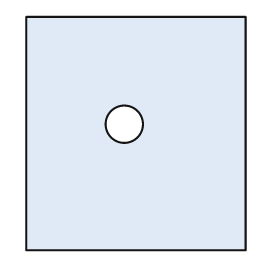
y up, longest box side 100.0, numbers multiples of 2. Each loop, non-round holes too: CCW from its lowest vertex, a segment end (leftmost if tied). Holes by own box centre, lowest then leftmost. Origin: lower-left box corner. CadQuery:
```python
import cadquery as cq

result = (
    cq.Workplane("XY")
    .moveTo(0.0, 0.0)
    .lineTo(94.0, 0.0)
    .lineTo(94.0, 100.0)
    .lineTo(0.0, 100.0)
    .close()
    .moveTo(42.0, 54.0)
    .circle(8.0)
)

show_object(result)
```